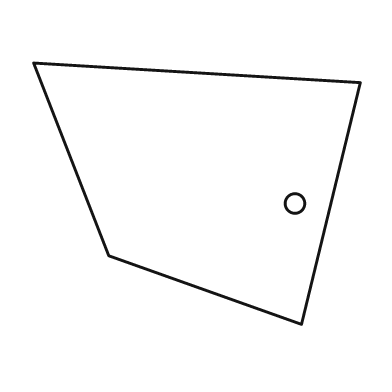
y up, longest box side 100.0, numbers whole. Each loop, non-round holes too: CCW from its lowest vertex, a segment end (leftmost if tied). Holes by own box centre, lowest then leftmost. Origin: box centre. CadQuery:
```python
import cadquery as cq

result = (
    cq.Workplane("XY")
    .moveTo(32.0, -40.0)
    .lineTo(50.0, 34.0)
    .lineTo(-50.0, 40.0)
    .lineTo(-27.0, -19.0)
    .close()
    .moveTo(30.0, -3.0)
    .circle(3.0)
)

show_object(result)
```